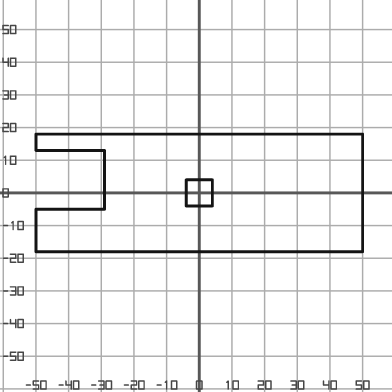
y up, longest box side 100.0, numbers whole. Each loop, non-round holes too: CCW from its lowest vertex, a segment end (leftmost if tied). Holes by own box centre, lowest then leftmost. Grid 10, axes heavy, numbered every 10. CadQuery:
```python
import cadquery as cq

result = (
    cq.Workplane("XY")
    .moveTo(-50.0, -18.0)
    .lineTo(50.0, -18.0)
    .lineTo(50.0, 18.0)
    .lineTo(-50.0, 18.0)
    .lineTo(-50.0, 13.0)
    .lineTo(-29.0, 13.0)
    .lineTo(-29.0, -5.0)
    .lineTo(-50.0, -5.0)
    .close()
    .moveTo(-4.0, -4.0)
    .lineTo(4.0, -4.0)
    .lineTo(4.0, 4.0)
    .lineTo(-4.0, 4.0)
    .close()
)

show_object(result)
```